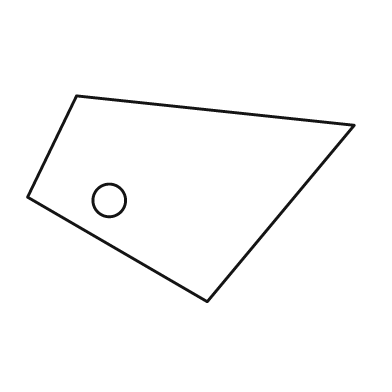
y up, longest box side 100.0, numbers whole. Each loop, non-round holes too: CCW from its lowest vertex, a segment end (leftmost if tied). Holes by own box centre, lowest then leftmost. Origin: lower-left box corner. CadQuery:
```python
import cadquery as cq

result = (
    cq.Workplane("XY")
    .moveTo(55.0, 0.0)
    .lineTo(100.0, 54.0)
    .lineTo(15.0, 63.0)
    .lineTo(0.0, 32.0)
    .close()
    .moveTo(25.0, 31.0)
    .circle(5.0)
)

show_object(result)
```